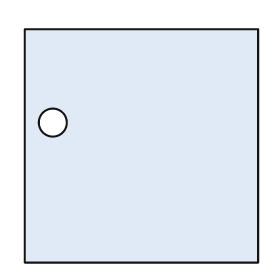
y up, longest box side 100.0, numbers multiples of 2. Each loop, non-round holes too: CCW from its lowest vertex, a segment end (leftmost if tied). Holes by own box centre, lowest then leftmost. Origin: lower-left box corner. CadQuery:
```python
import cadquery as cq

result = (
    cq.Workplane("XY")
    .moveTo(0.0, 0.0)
    .lineTo(100.0, 0.0)
    .lineTo(100.0, 100.0)
    .lineTo(0.0, 100.0)
    .close()
    .moveTo(12.0, 60.0)
    .circle(6.0)
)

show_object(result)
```